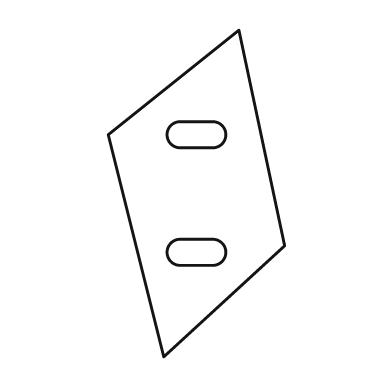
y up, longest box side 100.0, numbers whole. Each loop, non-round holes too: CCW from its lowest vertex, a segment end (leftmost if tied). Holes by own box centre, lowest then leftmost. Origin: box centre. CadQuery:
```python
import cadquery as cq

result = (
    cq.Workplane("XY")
    .moveTo(-10.0, -50.0)
    .lineTo(27.0, -16.0)
    .lineTo(13.0, 50.0)
    .lineTo(-27.0, 18.0)
    .close()
    .moveTo(-5.0, -22.0)
    .lineTo(5.0, -22.0)
    .threePointArc((9.0, -18.0), (5.0, -14.0))
    .lineTo(-5.0, -14.0)
    .threePointArc((-9.0, -18.0), (-5.0, -22.0))
    .close()
    .moveTo(-5.0, 14.0)
    .lineTo(5.0, 14.0)
    .threePointArc((9.0, 18.0), (5.0, 22.0))
    .lineTo(-5.0, 22.0)
    .threePointArc((-9.0, 18.0), (-5.0, 14.0))
    .close()
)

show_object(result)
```